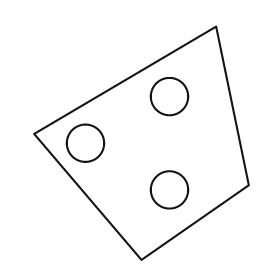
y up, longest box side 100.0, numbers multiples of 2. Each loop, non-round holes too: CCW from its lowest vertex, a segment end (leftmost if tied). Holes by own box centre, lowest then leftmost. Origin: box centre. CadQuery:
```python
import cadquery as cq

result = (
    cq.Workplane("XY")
    .moveTo(0.0, -50.0)
    .lineTo(46.0, -18.0)
    .lineTo(32.0, 50.0)
    .lineTo(-46.0, 4.0)
    .close()
    .moveTo(12.0, -20.0)
    .circle(8.0)
    .moveTo(-24.0, 0.0)
    .circle(8.0)
    .moveTo(12.0, 20.0)
    .circle(8.0)
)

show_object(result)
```